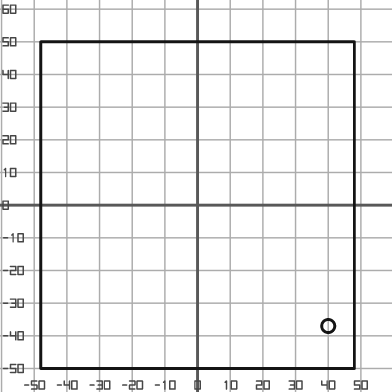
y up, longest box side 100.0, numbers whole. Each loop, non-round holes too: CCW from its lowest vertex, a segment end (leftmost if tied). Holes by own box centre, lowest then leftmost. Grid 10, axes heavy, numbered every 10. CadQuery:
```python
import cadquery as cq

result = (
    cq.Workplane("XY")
    .moveTo(-48.0, -50.0)
    .lineTo(48.0, -50.0)
    .lineTo(48.0, 50.0)
    .lineTo(-48.0, 50.0)
    .close()
    .moveTo(40.0, -37.0)
    .circle(2.0)
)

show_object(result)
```